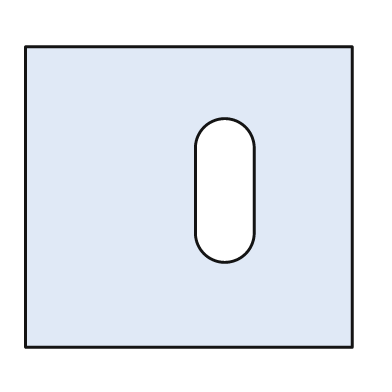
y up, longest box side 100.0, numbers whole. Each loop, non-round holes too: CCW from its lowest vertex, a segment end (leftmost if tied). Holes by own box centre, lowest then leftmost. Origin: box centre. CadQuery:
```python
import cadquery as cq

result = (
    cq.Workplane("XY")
    .moveTo(-50.0, -46.0)
    .lineTo(50.0, -46.0)
    .lineTo(50.0, 46.0)
    .lineTo(-50.0, 46.0)
    .close()
    .moveTo(2.0, -11.0)
    .threePointArc((11.0, -20.0), (20.0, -11.0))
    .lineTo(20.0, 15.0)
    .threePointArc((11.0, 24.0), (2.0, 15.0))
    .close()
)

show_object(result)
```